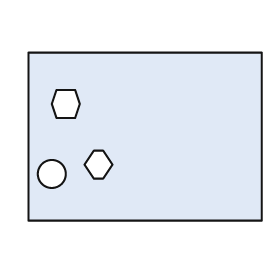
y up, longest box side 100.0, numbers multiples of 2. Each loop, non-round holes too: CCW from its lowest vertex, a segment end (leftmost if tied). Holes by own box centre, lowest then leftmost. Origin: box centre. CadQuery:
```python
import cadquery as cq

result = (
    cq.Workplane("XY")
    .moveTo(-50.0, -36.0)
    .lineTo(50.0, -36.0)
    .lineTo(50.0, 36.0)
    .lineTo(-50.0, 36.0)
    .close()
    .moveTo(-40.0, -16.0)
    .circle(6.0)
    .moveTo(-22.0, -18.0)
    .lineTo(-18.0, -18.0)
    .lineTo(-14.0, -12.0)
    .lineTo(-18.0, -6.0)
    .lineTo(-22.0, -6.0)
    .lineTo(-26.0, -12.0)
    .close()
    .moveTo(-38.0, 8.0)
    .lineTo(-30.0, 8.0)
    .lineTo(-28.0, 14.0)
    .lineTo(-30.0, 20.0)
    .lineTo(-38.0, 20.0)
    .lineTo(-40.0, 14.0)
    .close()
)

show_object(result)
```